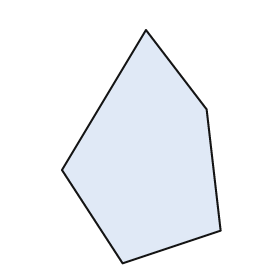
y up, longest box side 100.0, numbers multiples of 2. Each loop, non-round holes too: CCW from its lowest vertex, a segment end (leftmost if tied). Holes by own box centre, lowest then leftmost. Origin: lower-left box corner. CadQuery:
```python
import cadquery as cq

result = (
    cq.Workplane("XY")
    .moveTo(26.0, 0.0)
    .lineTo(68.0, 14.0)
    .lineTo(62.0, 66.0)
    .lineTo(36.0, 100.0)
    .lineTo(0.0, 40.0)
    .close()
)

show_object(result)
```